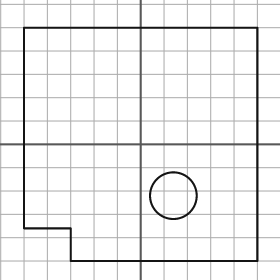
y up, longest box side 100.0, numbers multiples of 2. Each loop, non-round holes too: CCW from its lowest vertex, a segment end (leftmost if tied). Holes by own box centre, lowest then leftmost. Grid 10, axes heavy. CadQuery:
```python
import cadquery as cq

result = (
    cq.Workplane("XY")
    .moveTo(-30.0, -50.0)
    .lineTo(50.0, -50.0)
    .lineTo(50.0, 50.0)
    .lineTo(-50.0, 50.0)
    .lineTo(-50.0, -36.0)
    .lineTo(-30.0, -36.0)
    .close()
    .moveTo(14.0, -22.0)
    .circle(10.0)
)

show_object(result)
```